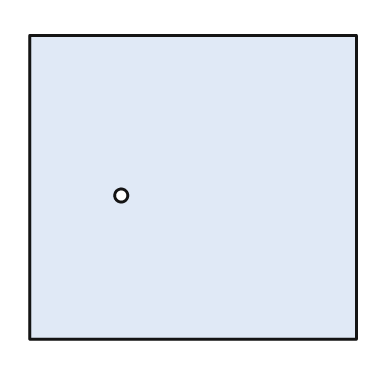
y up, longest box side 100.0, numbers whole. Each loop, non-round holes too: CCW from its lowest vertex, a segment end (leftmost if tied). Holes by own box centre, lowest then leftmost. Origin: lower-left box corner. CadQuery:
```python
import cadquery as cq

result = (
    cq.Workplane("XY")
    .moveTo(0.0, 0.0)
    .lineTo(100.0, 0.0)
    .lineTo(100.0, 93.0)
    .lineTo(0.0, 93.0)
    .close()
    .moveTo(28.0, 44.0)
    .circle(2.0)
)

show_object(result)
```